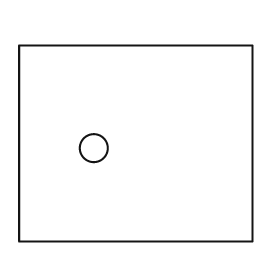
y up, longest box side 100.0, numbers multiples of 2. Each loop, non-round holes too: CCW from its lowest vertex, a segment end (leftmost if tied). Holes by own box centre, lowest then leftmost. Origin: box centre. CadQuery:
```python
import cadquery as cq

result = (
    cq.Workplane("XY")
    .moveTo(-50.0, -42.0)
    .lineTo(50.0, -42.0)
    .lineTo(50.0, 42.0)
    .lineTo(-50.0, 42.0)
    .close()
    .moveTo(-18.0, -2.0)
    .circle(6.0)
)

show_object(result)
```